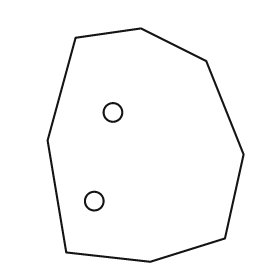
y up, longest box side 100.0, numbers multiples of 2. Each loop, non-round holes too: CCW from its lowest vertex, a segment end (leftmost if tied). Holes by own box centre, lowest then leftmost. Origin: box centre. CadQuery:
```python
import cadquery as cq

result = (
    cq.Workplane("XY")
    .moveTo(2.0, -50.0)
    .lineTo(34.0, -40.0)
    .lineTo(42.0, -4.0)
    .lineTo(26.0, 36.0)
    .lineTo(-2.0, 50.0)
    .lineTo(-30.0, 46.0)
    .lineTo(-42.0, 2.0)
    .lineTo(-34.0, -46.0)
    .close()
    .moveTo(-22.0, -24.0)
    .circle(4.0)
    .moveTo(-14.0, 14.0)
    .circle(4.0)
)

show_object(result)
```